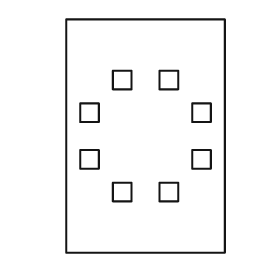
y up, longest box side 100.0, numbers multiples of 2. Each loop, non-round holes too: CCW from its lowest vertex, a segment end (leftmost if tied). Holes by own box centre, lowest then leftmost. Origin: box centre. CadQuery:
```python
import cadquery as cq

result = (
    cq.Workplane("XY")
    .moveTo(-34.0, -50.0)
    .lineTo(34.0, -50.0)
    .lineTo(34.0, 50.0)
    .lineTo(-34.0, 50.0)
    .close()
    .moveTo(-14.0, -28.0)
    .lineTo(-6.0, -28.0)
    .lineTo(-6.0, -20.0)
    .lineTo(-14.0, -20.0)
    .close()
    .moveTo(6.0, -28.0)
    .lineTo(14.0, -28.0)
    .lineTo(14.0, -20.0)
    .lineTo(6.0, -20.0)
    .close()
    .moveTo(-28.0, -14.0)
    .lineTo(-20.0, -14.0)
    .lineTo(-20.0, -6.0)
    .lineTo(-28.0, -6.0)
    .close()
    .moveTo(20.0, -14.0)
    .lineTo(28.0, -14.0)
    .lineTo(28.0, -6.0)
    .lineTo(20.0, -6.0)
    .close()
    .moveTo(-28.0, 6.0)
    .lineTo(-20.0, 6.0)
    .lineTo(-20.0, 14.0)
    .lineTo(-28.0, 14.0)
    .close()
    .moveTo(20.0, 6.0)
    .lineTo(28.0, 6.0)
    .lineTo(28.0, 14.0)
    .lineTo(20.0, 14.0)
    .close()
    .moveTo(-14.0, 20.0)
    .lineTo(-6.0, 20.0)
    .lineTo(-6.0, 28.0)
    .lineTo(-14.0, 28.0)
    .close()
    .moveTo(6.0, 20.0)
    .lineTo(14.0, 20.0)
    .lineTo(14.0, 28.0)
    .lineTo(6.0, 28.0)
    .close()
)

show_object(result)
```